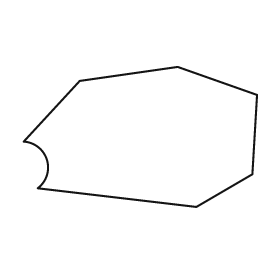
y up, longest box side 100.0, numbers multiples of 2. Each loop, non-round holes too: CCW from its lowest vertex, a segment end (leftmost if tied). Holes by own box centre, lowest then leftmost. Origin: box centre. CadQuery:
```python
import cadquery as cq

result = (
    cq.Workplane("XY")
    .moveTo(24.0, -30.0)
    .lineTo(48.0, -16.0)
    .lineTo(50.0, 18.0)
    .lineTo(16.0, 30.0)
    .lineTo(-26.0, 24.0)
    .lineTo(-50.0, -2.0)
    .threePointArc((-40.0, -10.0), (-44.0, -22.0))
    .close()
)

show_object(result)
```